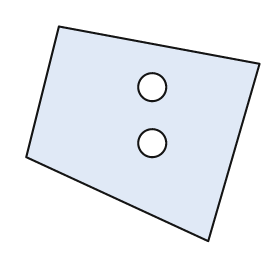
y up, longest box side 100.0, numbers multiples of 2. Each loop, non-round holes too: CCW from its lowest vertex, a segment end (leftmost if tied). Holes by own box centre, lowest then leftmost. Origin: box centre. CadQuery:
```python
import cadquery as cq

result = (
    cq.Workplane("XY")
    .moveTo(28.0, -46.0)
    .lineTo(50.0, 30.0)
    .lineTo(-36.0, 46.0)
    .lineTo(-50.0, -10.0)
    .close()
    .moveTo(4.0, -4.0)
    .circle(6.0)
    .moveTo(4.0, 20.0)
    .circle(6.0)
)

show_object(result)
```